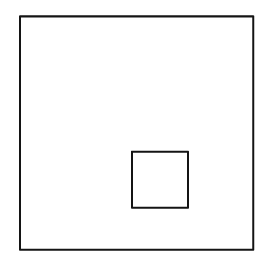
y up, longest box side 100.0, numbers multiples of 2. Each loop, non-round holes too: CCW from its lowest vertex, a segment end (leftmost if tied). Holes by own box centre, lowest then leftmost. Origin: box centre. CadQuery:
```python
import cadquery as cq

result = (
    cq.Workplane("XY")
    .moveTo(-50.0, -50.0)
    .lineTo(50.0, -50.0)
    .lineTo(50.0, 50.0)
    .lineTo(-50.0, 50.0)
    .close()
    .moveTo(-2.0, -32.0)
    .lineTo(22.0, -32.0)
    .lineTo(22.0, -8.0)
    .lineTo(-2.0, -8.0)
    .close()
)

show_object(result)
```